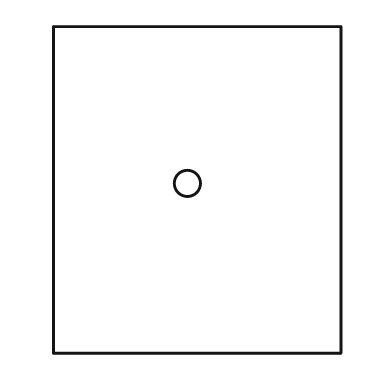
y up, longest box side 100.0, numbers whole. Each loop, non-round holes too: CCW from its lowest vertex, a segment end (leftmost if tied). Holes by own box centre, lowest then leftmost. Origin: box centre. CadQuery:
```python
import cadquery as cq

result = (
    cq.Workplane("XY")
    .moveTo(-44.0, -50.0)
    .lineTo(44.0, -50.0)
    .lineTo(44.0, 50.0)
    .lineTo(-44.0, 50.0)
    .close()
    .moveTo(-3.0, 2.0)
    .circle(4.0)
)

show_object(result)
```